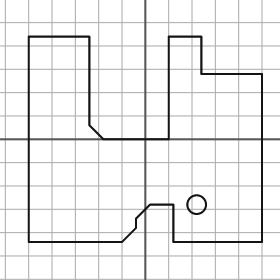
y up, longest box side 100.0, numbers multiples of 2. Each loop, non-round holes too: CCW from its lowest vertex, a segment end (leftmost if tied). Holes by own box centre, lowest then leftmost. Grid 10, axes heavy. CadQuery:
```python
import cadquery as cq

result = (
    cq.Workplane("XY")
    .moveTo(-50.0, -44.0)
    .lineTo(-10.0, -44.0)
    .lineTo(-4.0, -38.0)
    .lineTo(-4.0, -34.0)
    .lineTo(2.0, -28.0)
    .lineTo(12.0, -28.0)
    .lineTo(12.0, -44.0)
    .lineTo(50.0, -44.0)
    .lineTo(50.0, 28.0)
    .lineTo(24.0, 28.0)
    .lineTo(24.0, 44.0)
    .lineTo(10.0, 44.0)
    .lineTo(10.0, 0.0)
    .lineTo(-18.0, 0.0)
    .lineTo(-24.0, 6.0)
    .lineTo(-24.0, 44.0)
    .lineTo(-50.0, 44.0)
    .close()
    .moveTo(22.0, -28.0)
    .circle(4.0)
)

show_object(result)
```